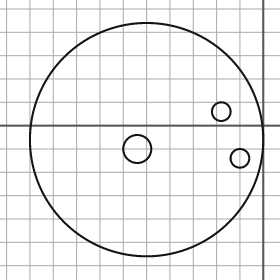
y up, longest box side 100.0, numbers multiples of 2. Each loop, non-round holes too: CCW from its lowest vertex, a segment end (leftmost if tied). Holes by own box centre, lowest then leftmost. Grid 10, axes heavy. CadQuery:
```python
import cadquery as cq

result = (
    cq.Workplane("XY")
    .moveTo(-50.0, -6.0)
    .circle(50.0)
    .moveTo(-10.0, -14.0)
    .circle(4.0)
    .moveTo(-54.0, -10.0)
    .circle(6.0)
    .moveTo(-18.0, 6.0)
    .circle(4.0)
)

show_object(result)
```